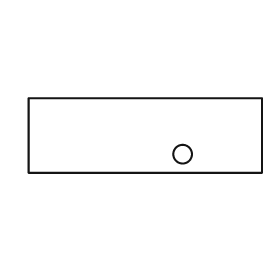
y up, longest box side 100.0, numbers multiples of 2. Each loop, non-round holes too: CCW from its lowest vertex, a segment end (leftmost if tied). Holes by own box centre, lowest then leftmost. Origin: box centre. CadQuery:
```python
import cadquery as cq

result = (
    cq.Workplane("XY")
    .moveTo(-50.0, -16.0)
    .lineTo(50.0, -16.0)
    .lineTo(50.0, 16.0)
    .lineTo(-50.0, 16.0)
    .close()
    .moveTo(16.0, -8.0)
    .circle(4.0)
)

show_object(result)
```